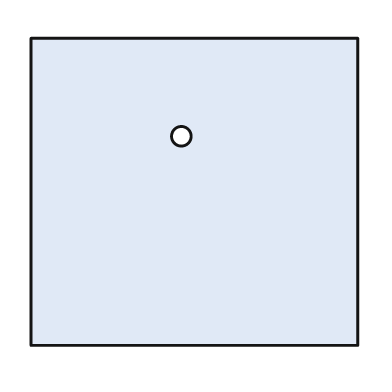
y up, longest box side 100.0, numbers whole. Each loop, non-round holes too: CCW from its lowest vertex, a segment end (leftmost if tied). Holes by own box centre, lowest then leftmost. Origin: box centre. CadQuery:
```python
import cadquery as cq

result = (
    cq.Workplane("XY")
    .moveTo(-50.0, -47.0)
    .lineTo(50.0, -47.0)
    .lineTo(50.0, 47.0)
    .lineTo(-50.0, 47.0)
    .close()
    .moveTo(-4.0, 17.0)
    .circle(3.0)
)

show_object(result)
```